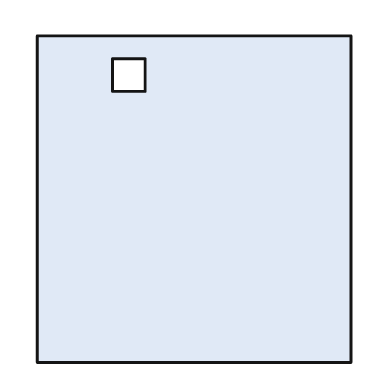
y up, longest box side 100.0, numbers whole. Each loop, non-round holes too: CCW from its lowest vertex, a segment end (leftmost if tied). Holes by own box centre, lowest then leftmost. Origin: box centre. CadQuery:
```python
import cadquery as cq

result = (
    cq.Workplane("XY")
    .moveTo(-48.0, -50.0)
    .lineTo(48.0, -50.0)
    .lineTo(48.0, 50.0)
    .lineTo(-48.0, 50.0)
    .close()
    .moveTo(-25.0, 33.0)
    .lineTo(-15.0, 33.0)
    .lineTo(-15.0, 43.0)
    .lineTo(-25.0, 43.0)
    .close()
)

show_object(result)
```